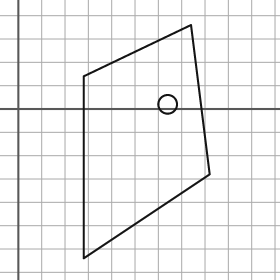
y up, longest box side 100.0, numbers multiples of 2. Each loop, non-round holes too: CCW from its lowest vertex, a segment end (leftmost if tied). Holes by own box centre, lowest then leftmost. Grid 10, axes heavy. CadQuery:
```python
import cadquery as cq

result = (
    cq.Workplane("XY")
    .moveTo(28.0, -64.0)
    .lineTo(82.0, -28.0)
    .lineTo(74.0, 36.0)
    .lineTo(28.0, 14.0)
    .close()
    .moveTo(64.0, 2.0)
    .circle(4.0)
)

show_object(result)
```